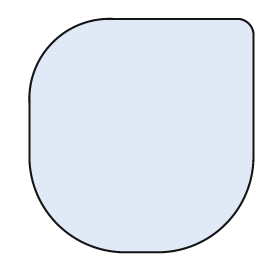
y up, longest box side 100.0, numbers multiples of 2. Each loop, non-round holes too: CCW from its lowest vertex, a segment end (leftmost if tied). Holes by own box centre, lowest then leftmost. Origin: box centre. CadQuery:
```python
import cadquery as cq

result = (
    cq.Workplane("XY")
    .moveTo(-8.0, -50.0)
    .lineTo(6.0, -50.0)
    .threePointArc((36.0, -38.0), (48.0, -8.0))
    .lineTo(48.0, 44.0)
    .threePointArc((46.0, 48.0), (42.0, 50.0))
    .lineTo(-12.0, 50.0)
    .threePointArc((-38.0, 40.0), (-48.0, 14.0))
    .lineTo(-48.0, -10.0)
    .threePointArc((-36.0, -38.0), (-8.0, -50.0))
    .close()
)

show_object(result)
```